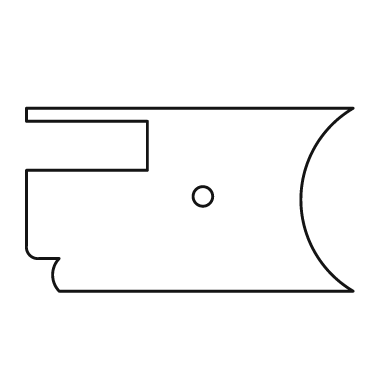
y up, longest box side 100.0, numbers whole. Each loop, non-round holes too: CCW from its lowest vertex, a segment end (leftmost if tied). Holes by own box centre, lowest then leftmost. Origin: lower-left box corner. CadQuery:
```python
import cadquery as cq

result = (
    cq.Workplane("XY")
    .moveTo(10.0, 0.0)
    .lineTo(100.0, 0.0)
    .threePointArc((84.0, 28.0), (100.0, 56.0))
    .lineTo(0.0, 56.0)
    .lineTo(0.0, 52.0)
    .lineTo(37.0, 52.0)
    .lineTo(37.0, 37.0)
    .lineTo(0.0, 37.0)
    .lineTo(0.0, 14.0)
    .threePointArc((1.0, 11.0), (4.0, 10.0))
    .lineTo(10.0, 10.0)
    .threePointArc((8.0, 5.0), (10.0, 0.0))
    .close()
    .moveTo(54.0, 29.0)
    .circle(3.0)
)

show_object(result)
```